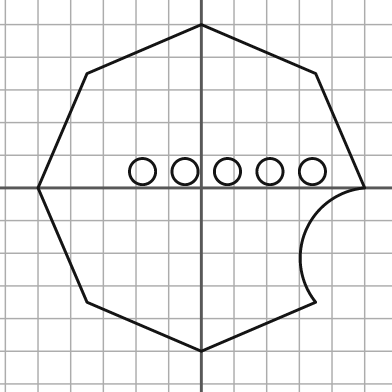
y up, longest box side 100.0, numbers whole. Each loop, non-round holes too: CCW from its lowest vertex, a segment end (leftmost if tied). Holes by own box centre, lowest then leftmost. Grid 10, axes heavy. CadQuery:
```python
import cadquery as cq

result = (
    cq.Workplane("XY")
    .moveTo(0.0, -50.0)
    .lineTo(35.0, -35.0)
    .threePointArc((32.0, -13.0), (50.0, 0.0))
    .lineTo(35.0, 35.0)
    .lineTo(0.0, 50.0)
    .lineTo(-35.0, 35.0)
    .lineTo(-50.0, 0.0)
    .lineTo(-35.0, -35.0)
    .close()
    .moveTo(-18.0, 5.0)
    .circle(4.0)
    .moveTo(-5.0, 5.0)
    .circle(4.0)
    .moveTo(8.0, 5.0)
    .circle(4.0)
    .moveTo(21.0, 5.0)
    .circle(4.0)
    .moveTo(34.0, 5.0)
    .circle(4.0)
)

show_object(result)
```